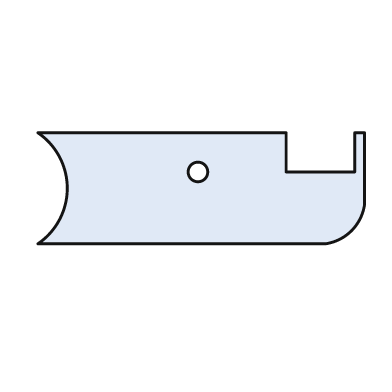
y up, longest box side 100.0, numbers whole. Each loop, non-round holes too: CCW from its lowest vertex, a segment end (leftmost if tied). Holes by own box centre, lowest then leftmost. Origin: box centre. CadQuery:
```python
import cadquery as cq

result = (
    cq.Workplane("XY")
    .moveTo(-50.0, -17.0)
    .lineTo(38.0, -17.0)
    .threePointArc((46.0, -13.0), (50.0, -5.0))
    .lineTo(50.0, 17.0)
    .lineTo(47.0, 17.0)
    .lineTo(47.0, 5.0)
    .lineTo(26.0, 5.0)
    .lineTo(26.0, 17.0)
    .lineTo(-50.0, 17.0)
    .threePointArc((-41.0, 0.0), (-50.0, -17.0))
    .close()
    .moveTo(-1.0, 5.0)
    .circle(3.0)
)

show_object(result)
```